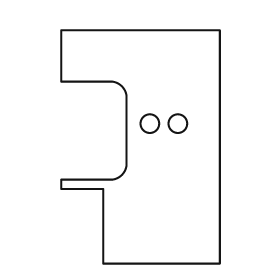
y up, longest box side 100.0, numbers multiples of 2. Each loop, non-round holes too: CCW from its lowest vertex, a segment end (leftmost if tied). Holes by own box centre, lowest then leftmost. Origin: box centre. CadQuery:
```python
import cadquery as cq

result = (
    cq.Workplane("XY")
    .moveTo(-16.0, -50.0)
    .lineTo(34.0, -50.0)
    .lineTo(34.0, 50.0)
    .lineTo(-34.0, 50.0)
    .lineTo(-34.0, 28.0)
    .lineTo(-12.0, 28.0)
    .threePointArc((-8.0, 26.0), (-6.0, 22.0))
    .lineTo(-6.0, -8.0)
    .threePointArc((-8.0, -12.0), (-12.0, -14.0))
    .lineTo(-34.0, -14.0)
    .lineTo(-34.0, -18.0)
    .lineTo(-16.0, -18.0)
    .close()
    .moveTo(4.0, 10.0)
    .circle(4.0)
    .moveTo(16.0, 10.0)
    .circle(4.0)
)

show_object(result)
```